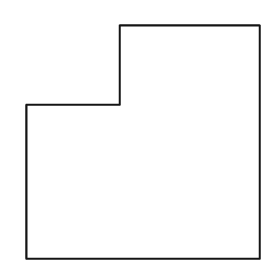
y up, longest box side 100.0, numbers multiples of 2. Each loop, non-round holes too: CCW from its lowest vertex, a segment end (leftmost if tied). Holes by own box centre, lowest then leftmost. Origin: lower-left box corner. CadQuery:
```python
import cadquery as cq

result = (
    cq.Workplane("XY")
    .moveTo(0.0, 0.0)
    .lineTo(100.0, 0.0)
    .lineTo(100.0, 100.0)
    .lineTo(40.0, 100.0)
    .lineTo(40.0, 66.0)
    .lineTo(0.0, 66.0)
    .close()
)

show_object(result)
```